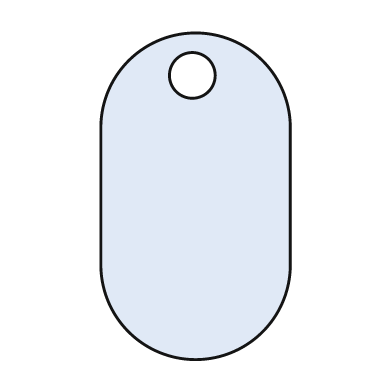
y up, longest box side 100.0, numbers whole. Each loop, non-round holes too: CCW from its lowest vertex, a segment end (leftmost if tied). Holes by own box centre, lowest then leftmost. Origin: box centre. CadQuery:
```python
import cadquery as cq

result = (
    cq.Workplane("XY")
    .moveTo(-29.0, -21.0)
    .threePointArc((0.0, -50.0), (29.0, -21.0))
    .lineTo(29.0, 21.0)
    .threePointArc((0.0, 50.0), (-29.0, 21.0))
    .close()
    .moveTo(-1.0, 37.0)
    .circle(7.0)
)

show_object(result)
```